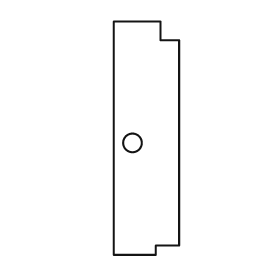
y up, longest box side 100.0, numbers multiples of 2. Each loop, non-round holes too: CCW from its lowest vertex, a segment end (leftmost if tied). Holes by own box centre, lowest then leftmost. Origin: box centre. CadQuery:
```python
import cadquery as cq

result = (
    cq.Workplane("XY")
    .moveTo(-14.0, -50.0)
    .lineTo(4.0, -50.0)
    .lineTo(4.0, -46.0)
    .lineTo(14.0, -46.0)
    .lineTo(14.0, 42.0)
    .lineTo(6.0, 42.0)
    .lineTo(6.0, 50.0)
    .lineTo(-14.0, 50.0)
    .close()
    .moveTo(-6.0, -2.0)
    .circle(4.0)
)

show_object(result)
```